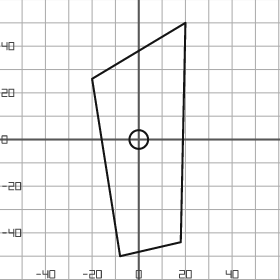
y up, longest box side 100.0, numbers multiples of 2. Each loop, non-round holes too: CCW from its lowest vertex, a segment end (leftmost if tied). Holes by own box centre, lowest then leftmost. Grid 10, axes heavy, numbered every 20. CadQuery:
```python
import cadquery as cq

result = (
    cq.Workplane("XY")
    .moveTo(-8.0, -50.0)
    .lineTo(18.0, -44.0)
    .lineTo(20.0, 50.0)
    .lineTo(-20.0, 26.0)
    .close()
    .moveTo(0.0, 0.0)
    .circle(4.0)
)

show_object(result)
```